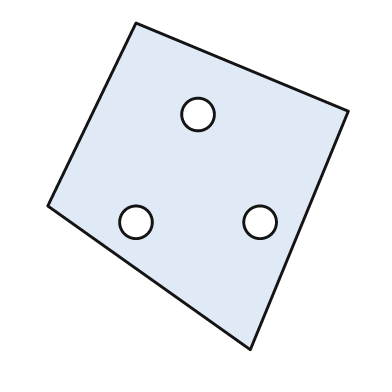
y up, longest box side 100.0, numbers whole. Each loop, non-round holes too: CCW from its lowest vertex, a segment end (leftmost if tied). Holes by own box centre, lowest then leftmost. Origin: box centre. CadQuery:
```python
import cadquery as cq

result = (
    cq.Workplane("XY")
    .moveTo(16.0, -50.0)
    .lineTo(46.0, 23.0)
    .lineTo(-19.0, 50.0)
    .lineTo(-46.0, -6.0)
    .close()
    .moveTo(-19.0, -11.0)
    .circle(5.0)
    .moveTo(19.0, -11.0)
    .circle(5.0)
    .moveTo(0.0, 22.0)
    .circle(5.0)
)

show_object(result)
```